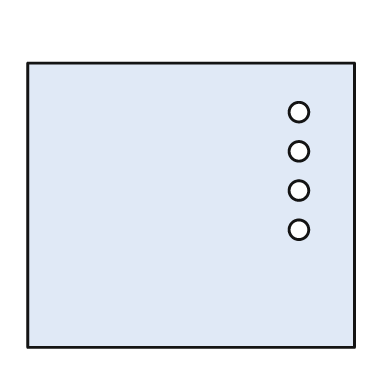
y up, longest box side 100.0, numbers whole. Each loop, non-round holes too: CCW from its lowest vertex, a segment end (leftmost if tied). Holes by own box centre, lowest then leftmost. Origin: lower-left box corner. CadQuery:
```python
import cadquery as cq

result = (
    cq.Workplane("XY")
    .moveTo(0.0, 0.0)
    .lineTo(100.0, 0.0)
    .lineTo(100.0, 87.0)
    .lineTo(0.0, 87.0)
    .close()
    .moveTo(83.0, 36.0)
    .circle(3.0)
    .moveTo(83.0, 48.0)
    .circle(3.0)
    .moveTo(83.0, 60.0)
    .circle(3.0)
    .moveTo(83.0, 72.0)
    .circle(3.0)
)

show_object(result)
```